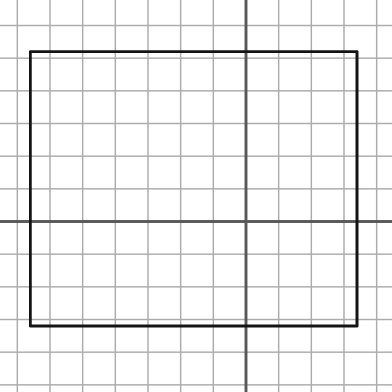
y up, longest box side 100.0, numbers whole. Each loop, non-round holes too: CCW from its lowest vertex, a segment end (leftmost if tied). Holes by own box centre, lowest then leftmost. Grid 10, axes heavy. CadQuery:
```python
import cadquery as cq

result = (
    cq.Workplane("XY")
    .moveTo(-66.0, -32.0)
    .lineTo(34.0, -32.0)
    .lineTo(34.0, 52.0)
    .lineTo(-66.0, 52.0)
    .close()
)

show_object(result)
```